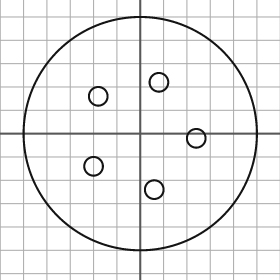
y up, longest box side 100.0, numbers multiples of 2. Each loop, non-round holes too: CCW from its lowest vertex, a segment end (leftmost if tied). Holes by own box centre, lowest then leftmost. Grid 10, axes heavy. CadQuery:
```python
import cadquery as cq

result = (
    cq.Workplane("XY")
    .moveTo(0.0, 0.0)
    .circle(50.0)
    .moveTo(6.0, -24.0)
    .circle(4.0)
    .moveTo(-20.0, -14.0)
    .circle(4.0)
    .moveTo(24.0, -2.0)
    .circle(4.0)
    .moveTo(-18.0, 16.0)
    .circle(4.0)
    .moveTo(8.0, 22.0)
    .circle(4.0)
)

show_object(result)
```